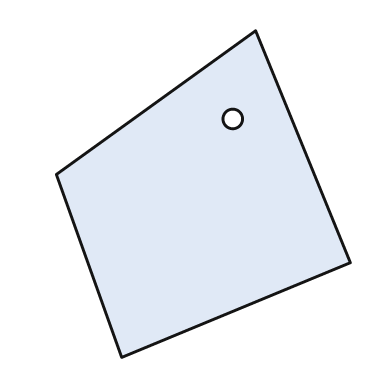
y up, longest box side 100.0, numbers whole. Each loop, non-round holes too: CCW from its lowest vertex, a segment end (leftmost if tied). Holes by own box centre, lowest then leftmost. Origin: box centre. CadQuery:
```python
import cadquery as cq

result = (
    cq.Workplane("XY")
    .moveTo(-25.0, -50.0)
    .lineTo(45.0, -21.0)
    .lineTo(16.0, 50.0)
    .lineTo(-45.0, 6.0)
    .close()
    .moveTo(9.0, 23.0)
    .circle(3.0)
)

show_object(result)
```